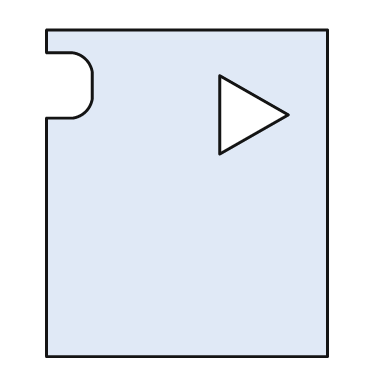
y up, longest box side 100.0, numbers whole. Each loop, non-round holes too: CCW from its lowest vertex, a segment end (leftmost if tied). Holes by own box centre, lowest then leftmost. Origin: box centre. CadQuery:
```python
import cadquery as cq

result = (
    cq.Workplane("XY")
    .moveTo(-43.0, -50.0)
    .lineTo(43.0, -50.0)
    .lineTo(43.0, 50.0)
    .lineTo(-43.0, 50.0)
    .lineTo(-43.0, 43.0)
    .lineTo(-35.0, 43.0)
    .threePointArc((-31.0, 41.0), (-29.0, 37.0))
    .lineTo(-29.0, 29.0)
    .threePointArc((-31.0, 25.0), (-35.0, 23.0))
    .lineTo(-43.0, 23.0)
    .close()
    .moveTo(10.0, 12.0)
    .lineTo(31.0, 24.0)
    .lineTo(10.0, 36.0)
    .close()
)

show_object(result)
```